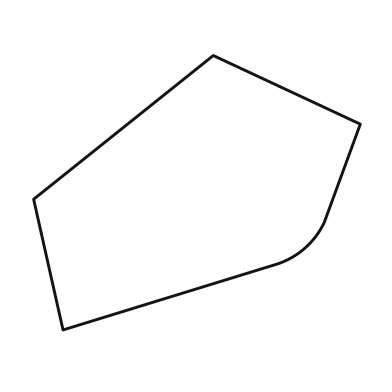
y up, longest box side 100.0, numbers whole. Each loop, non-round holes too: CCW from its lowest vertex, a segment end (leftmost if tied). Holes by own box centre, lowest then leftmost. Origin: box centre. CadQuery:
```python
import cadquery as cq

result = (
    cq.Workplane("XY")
    .moveTo(-41.0, -42.0)
    .lineTo(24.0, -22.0)
    .threePointArc((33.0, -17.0), (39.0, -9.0))
    .lineTo(50.0, 21.0)
    .lineTo(5.0, 42.0)
    .lineTo(-50.0, -2.0)
    .close()
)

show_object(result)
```